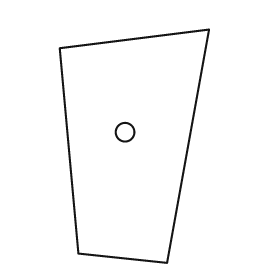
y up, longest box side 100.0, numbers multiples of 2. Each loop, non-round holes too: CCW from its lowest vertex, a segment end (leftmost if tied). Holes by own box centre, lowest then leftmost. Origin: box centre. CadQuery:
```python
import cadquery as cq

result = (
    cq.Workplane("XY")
    .moveTo(14.0, -50.0)
    .lineTo(32.0, 50.0)
    .lineTo(-32.0, 42.0)
    .lineTo(-24.0, -46.0)
    .close()
    .moveTo(-4.0, 6.0)
    .circle(4.0)
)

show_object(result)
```